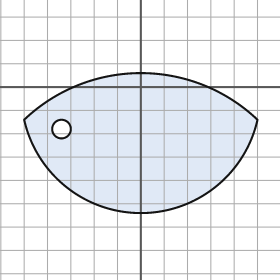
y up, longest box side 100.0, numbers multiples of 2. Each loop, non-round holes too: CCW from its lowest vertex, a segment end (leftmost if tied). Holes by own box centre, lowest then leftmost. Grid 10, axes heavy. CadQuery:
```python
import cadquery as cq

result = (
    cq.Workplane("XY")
    .moveTo(-50.0, -14.0)
    .threePointArc((0.0, -54.0), (50.0, -14.0))
    .threePointArc((0.0, 6.0), (-50.0, -14.0))
    .close()
    .moveTo(-34.0, -18.0)
    .circle(4.0)
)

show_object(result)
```